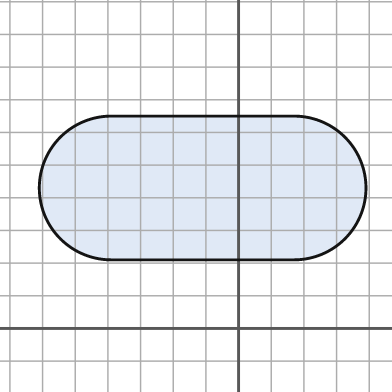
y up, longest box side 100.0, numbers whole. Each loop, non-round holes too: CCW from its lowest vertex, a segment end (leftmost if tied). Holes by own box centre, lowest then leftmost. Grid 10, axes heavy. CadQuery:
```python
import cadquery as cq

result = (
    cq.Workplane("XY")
    .moveTo(-39.0, 21.0)
    .lineTo(17.0, 21.0)
    .threePointArc((39.0, 43.0), (17.0, 65.0))
    .lineTo(-39.0, 65.0)
    .threePointArc((-61.0, 43.0), (-39.0, 21.0))
    .close()
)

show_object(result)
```